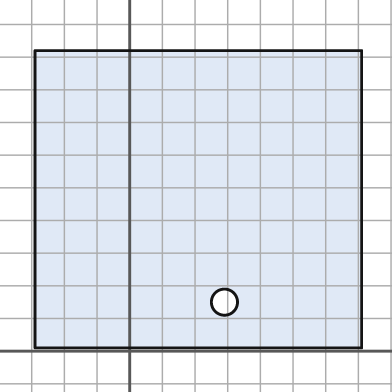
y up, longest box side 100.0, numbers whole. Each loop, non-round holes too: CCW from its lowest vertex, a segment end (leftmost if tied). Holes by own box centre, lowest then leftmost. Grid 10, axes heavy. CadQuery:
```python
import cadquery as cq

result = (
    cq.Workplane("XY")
    .moveTo(-29.0, 1.0)
    .lineTo(71.0, 1.0)
    .lineTo(71.0, 92.0)
    .lineTo(-29.0, 92.0)
    .close()
    .moveTo(29.0, 15.0)
    .circle(4.0)
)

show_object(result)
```